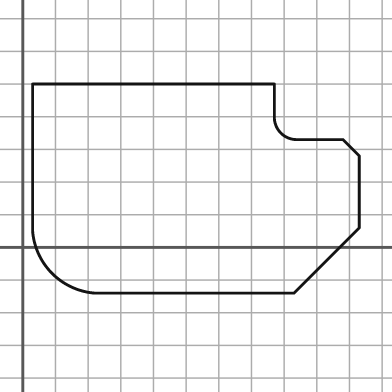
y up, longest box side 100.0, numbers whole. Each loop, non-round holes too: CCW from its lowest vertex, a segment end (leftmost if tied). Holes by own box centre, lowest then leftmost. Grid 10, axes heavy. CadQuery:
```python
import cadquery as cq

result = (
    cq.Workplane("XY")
    .moveTo(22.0, -14.0)
    .lineTo(83.0, -14.0)
    .lineTo(103.0, 6.0)
    .lineTo(103.0, 28.0)
    .lineTo(98.0, 33.0)
    .lineTo(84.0, 33.0)
    .threePointArc((79.0, 35.0), (77.0, 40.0))
    .lineTo(77.0, 50.0)
    .lineTo(3.0, 50.0)
    .lineTo(3.0, 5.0)
    .threePointArc((9.0, -8.0), (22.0, -14.0))
    .close()
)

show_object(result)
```